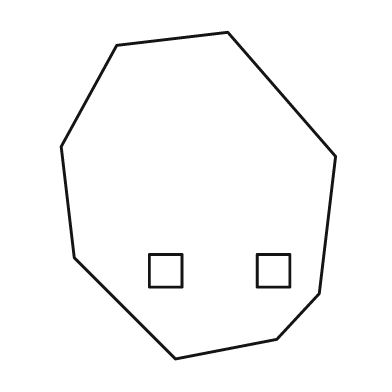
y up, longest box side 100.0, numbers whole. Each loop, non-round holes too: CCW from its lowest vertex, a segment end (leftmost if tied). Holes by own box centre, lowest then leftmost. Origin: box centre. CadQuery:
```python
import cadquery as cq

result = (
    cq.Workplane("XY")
    .moveTo(-7.0, -50.0)
    .lineTo(24.0, -44.0)
    .lineTo(37.0, -30.0)
    .lineTo(42.0, 12.0)
    .lineTo(9.0, 50.0)
    .lineTo(-25.0, 46.0)
    .lineTo(-42.0, 15.0)
    .lineTo(-38.0, -19.0)
    .close()
    .moveTo(-15.0, -28.0)
    .lineTo(-5.0, -28.0)
    .lineTo(-5.0, -18.0)
    .lineTo(-15.0, -18.0)
    .close()
    .moveTo(18.0, -28.0)
    .lineTo(28.0, -28.0)
    .lineTo(28.0, -18.0)
    .lineTo(18.0, -18.0)
    .close()
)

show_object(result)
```